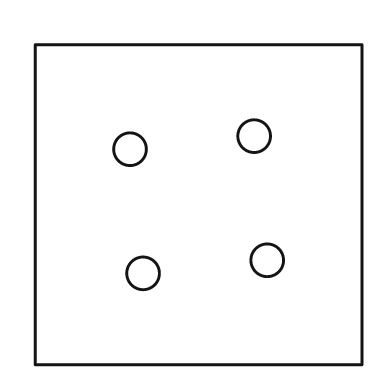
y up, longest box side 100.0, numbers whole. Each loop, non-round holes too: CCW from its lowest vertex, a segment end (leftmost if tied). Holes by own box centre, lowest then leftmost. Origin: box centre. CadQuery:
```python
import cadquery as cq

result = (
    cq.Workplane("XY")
    .moveTo(-50.0, -49.0)
    .lineTo(50.0, -49.0)
    .lineTo(50.0, 49.0)
    .lineTo(-50.0, 49.0)
    .close()
    .moveTo(-17.0, -21.0)
    .circle(5.0)
    .moveTo(21.0, -17.0)
    .circle(5.0)
    .moveTo(-21.0, 17.0)
    .circle(5.0)
    .moveTo(17.0, 21.0)
    .circle(5.0)
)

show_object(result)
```